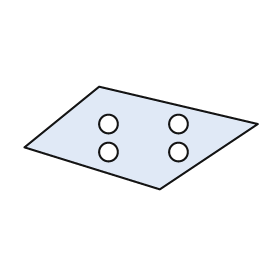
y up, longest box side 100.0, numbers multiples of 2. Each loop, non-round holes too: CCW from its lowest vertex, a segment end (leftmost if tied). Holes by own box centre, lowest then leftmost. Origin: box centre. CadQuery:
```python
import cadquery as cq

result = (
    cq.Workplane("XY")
    .moveTo(8.0, -22.0)
    .lineTo(50.0, 6.0)
    .lineTo(-18.0, 22.0)
    .lineTo(-50.0, -4.0)
    .close()
    .moveTo(-14.0, -6.0)
    .circle(4.0)
    .moveTo(16.0, -6.0)
    .circle(4.0)
    .moveTo(-14.0, 6.0)
    .circle(4.0)
    .moveTo(16.0, 6.0)
    .circle(4.0)
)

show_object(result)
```